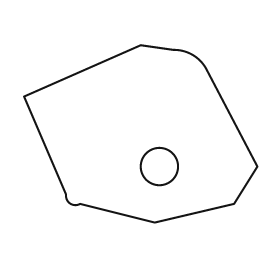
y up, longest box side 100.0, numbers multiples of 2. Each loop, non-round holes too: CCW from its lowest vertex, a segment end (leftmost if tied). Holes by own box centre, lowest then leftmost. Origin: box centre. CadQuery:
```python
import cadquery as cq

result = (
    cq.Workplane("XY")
    .moveTo(6.0, -38.0)
    .lineTo(40.0, -30.0)
    .lineTo(50.0, -14.0)
    .lineTo(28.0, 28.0)
    .threePointArc((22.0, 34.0), (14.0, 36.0))
    .lineTo(0.0, 38.0)
    .lineTo(-50.0, 16.0)
    .lineTo(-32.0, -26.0)
    .threePointArc((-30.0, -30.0), (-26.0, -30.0))
    .close()
    .moveTo(8.0, -14.0)
    .circle(8.0)
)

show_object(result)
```